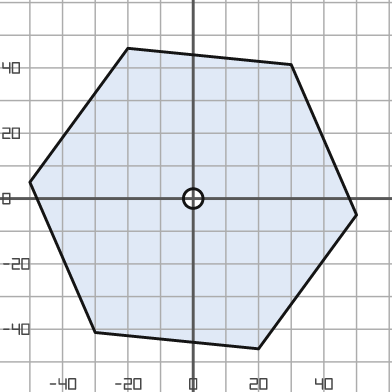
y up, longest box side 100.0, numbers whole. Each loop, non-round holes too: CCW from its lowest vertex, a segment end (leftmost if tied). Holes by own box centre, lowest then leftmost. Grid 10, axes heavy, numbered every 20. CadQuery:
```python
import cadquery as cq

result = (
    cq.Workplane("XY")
    .moveTo(20.0, -46.0)
    .lineTo(50.0, -5.0)
    .lineTo(30.0, 41.0)
    .lineTo(-20.0, 46.0)
    .lineTo(-50.0, 5.0)
    .lineTo(-30.0, -41.0)
    .close()
    .moveTo(0.0, 0.0)
    .circle(3.0)
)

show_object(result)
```